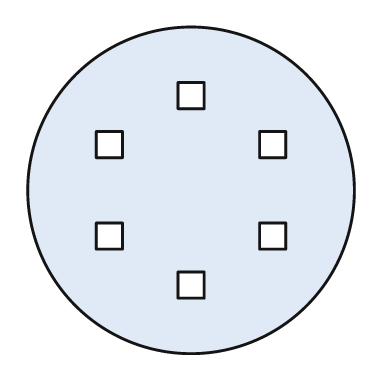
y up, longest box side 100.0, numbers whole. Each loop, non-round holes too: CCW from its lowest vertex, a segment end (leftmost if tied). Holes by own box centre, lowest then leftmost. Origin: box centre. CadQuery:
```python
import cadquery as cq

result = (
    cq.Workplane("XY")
    .moveTo(0.0, 0.0)
    .circle(50.0)
    .moveTo(-4.0, -33.0)
    .lineTo(4.0, -33.0)
    .lineTo(4.0, -25.0)
    .lineTo(-4.0, -25.0)
    .close()
    .moveTo(-29.0, -18.0)
    .lineTo(-21.0, -18.0)
    .lineTo(-21.0, -10.0)
    .lineTo(-29.0, -10.0)
    .close()
    .moveTo(21.0, -18.0)
    .lineTo(29.0, -18.0)
    .lineTo(29.0, -10.0)
    .lineTo(21.0, -10.0)
    .close()
    .moveTo(-29.0, 10.0)
    .lineTo(-21.0, 10.0)
    .lineTo(-21.0, 18.0)
    .lineTo(-29.0, 18.0)
    .close()
    .moveTo(21.0, 10.0)
    .lineTo(29.0, 10.0)
    .lineTo(29.0, 18.0)
    .lineTo(21.0, 18.0)
    .close()
    .moveTo(-4.0, 25.0)
    .lineTo(4.0, 25.0)
    .lineTo(4.0, 33.0)
    .lineTo(-4.0, 33.0)
    .close()
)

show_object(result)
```